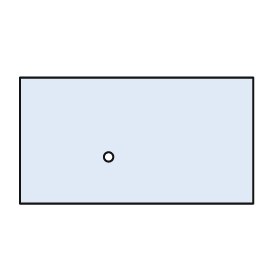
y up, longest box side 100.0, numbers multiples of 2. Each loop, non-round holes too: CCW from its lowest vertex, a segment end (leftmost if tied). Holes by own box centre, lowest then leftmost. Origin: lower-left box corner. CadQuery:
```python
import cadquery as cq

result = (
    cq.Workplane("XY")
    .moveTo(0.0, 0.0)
    .lineTo(100.0, 0.0)
    .lineTo(100.0, 54.0)
    .lineTo(0.0, 54.0)
    .close()
    .moveTo(38.0, 20.0)
    .circle(2.0)
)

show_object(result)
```